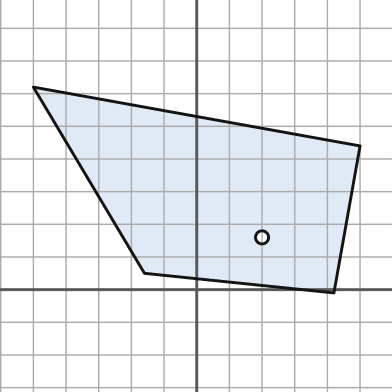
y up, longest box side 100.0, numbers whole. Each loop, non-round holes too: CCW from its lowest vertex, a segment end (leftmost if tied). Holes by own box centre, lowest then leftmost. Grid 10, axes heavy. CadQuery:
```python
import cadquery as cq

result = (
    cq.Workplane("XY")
    .moveTo(42.0, -1.0)
    .lineTo(50.0, 44.0)
    .lineTo(-50.0, 62.0)
    .lineTo(-16.0, 5.0)
    .close()
    .moveTo(20.0, 16.0)
    .circle(2.0)
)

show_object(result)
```